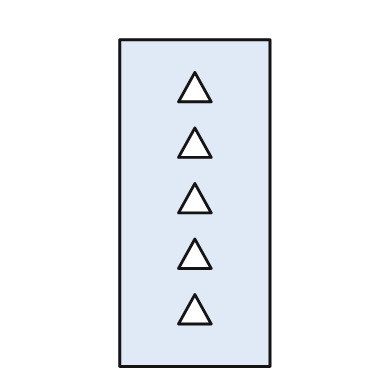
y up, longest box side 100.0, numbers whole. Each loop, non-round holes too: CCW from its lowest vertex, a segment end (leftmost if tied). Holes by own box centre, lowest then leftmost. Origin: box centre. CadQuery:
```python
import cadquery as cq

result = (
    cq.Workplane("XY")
    .moveTo(-23.0, -50.0)
    .lineTo(23.0, -50.0)
    .lineTo(23.0, 50.0)
    .lineTo(-23.0, 50.0)
    .close()
    .moveTo(-5.0, -37.0)
    .lineTo(5.0, -37.0)
    .lineTo(0.0, -28.0)
    .close()
    .moveTo(-5.0, -20.0)
    .lineTo(5.0, -20.0)
    .lineTo(0.0, -11.0)
    .close()
    .moveTo(-5.0, -3.0)
    .lineTo(5.0, -3.0)
    .lineTo(0.0, 6.0)
    .close()
    .moveTo(-5.0, 14.0)
    .lineTo(5.0, 14.0)
    .lineTo(0.0, 23.0)
    .close()
    .moveTo(-5.0, 31.0)
    .lineTo(5.0, 31.0)
    .lineTo(0.0, 40.0)
    .close()
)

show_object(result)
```